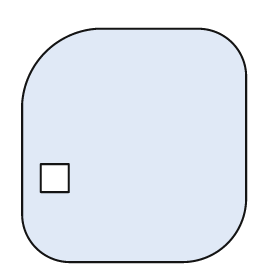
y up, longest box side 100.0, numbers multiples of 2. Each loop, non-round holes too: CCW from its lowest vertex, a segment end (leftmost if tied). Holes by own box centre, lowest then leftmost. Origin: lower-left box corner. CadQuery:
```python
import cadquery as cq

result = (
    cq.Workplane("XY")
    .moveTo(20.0, 0.0)
    .lineTo(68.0, 0.0)
    .threePointArc((88.0, 8.0), (96.0, 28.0))
    .lineTo(96.0, 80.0)
    .threePointArc((90.0, 94.0), (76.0, 100.0))
    .lineTo(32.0, 100.0)
    .threePointArc((10.0, 90.0), (0.0, 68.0))
    .lineTo(0.0, 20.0)
    .threePointArc((6.0, 6.0), (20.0, 0.0))
    .close()
    .moveTo(8.0, 30.0)
    .lineTo(20.0, 30.0)
    .lineTo(20.0, 42.0)
    .lineTo(8.0, 42.0)
    .close()
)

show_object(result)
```